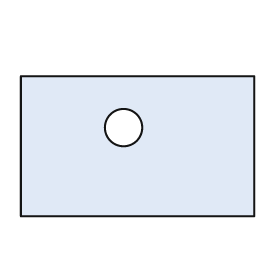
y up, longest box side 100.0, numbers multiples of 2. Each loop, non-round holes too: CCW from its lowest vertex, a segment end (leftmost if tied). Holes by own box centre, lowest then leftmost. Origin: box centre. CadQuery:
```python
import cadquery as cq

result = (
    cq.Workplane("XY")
    .moveTo(-50.0, -30.0)
    .lineTo(50.0, -30.0)
    .lineTo(50.0, 30.0)
    .lineTo(-50.0, 30.0)
    .close()
    .moveTo(-6.0, 8.0)
    .circle(8.0)
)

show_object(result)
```